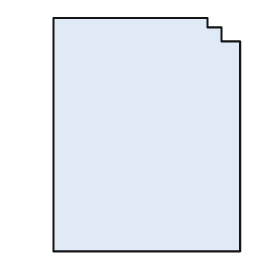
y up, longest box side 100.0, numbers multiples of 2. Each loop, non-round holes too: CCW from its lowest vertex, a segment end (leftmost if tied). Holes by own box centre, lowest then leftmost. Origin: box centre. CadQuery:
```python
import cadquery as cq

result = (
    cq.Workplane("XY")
    .moveTo(-40.0, -50.0)
    .lineTo(40.0, -50.0)
    .lineTo(40.0, 40.0)
    .lineTo(32.0, 40.0)
    .lineTo(32.0, 46.0)
    .lineTo(26.0, 46.0)
    .lineTo(26.0, 50.0)
    .lineTo(-40.0, 50.0)
    .close()
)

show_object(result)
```